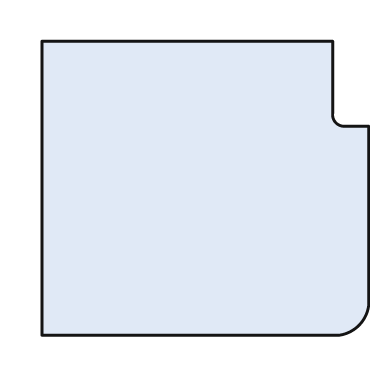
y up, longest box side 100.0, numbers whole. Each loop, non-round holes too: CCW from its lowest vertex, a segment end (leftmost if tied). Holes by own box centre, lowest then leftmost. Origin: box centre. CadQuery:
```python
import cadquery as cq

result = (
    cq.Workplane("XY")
    .moveTo(-50.0, -45.0)
    .lineTo(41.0, -45.0)
    .threePointArc((47.0, -42.0), (50.0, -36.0))
    .lineTo(50.0, 19.0)
    .lineTo(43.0, 19.0)
    .threePointArc((40.0, 20.0), (39.0, 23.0))
    .lineTo(39.0, 45.0)
    .lineTo(-50.0, 45.0)
    .close()
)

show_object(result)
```